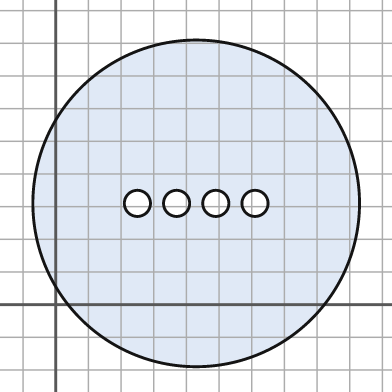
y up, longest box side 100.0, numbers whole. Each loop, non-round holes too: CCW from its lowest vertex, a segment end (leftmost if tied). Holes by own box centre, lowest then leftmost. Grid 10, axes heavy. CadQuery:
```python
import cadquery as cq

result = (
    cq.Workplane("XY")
    .moveTo(43.0, 31.0)
    .circle(50.0)
    .moveTo(25.0, 31.0)
    .circle(4.0)
    .moveTo(37.0, 31.0)
    .circle(4.0)
    .moveTo(49.0, 31.0)
    .circle(4.0)
    .moveTo(61.0, 31.0)
    .circle(4.0)
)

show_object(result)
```